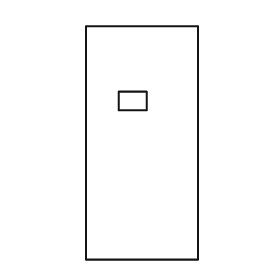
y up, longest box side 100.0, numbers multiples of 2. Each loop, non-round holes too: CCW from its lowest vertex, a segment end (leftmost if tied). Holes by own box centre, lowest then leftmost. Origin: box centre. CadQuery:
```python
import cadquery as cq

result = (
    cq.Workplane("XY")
    .moveTo(-24.0, -50.0)
    .lineTo(24.0, -50.0)
    .lineTo(24.0, 50.0)
    .lineTo(-24.0, 50.0)
    .close()
    .moveTo(-10.0, 14.0)
    .lineTo(2.0, 14.0)
    .lineTo(2.0, 22.0)
    .lineTo(-10.0, 22.0)
    .close()
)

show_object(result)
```